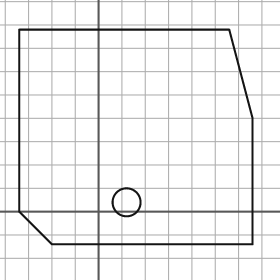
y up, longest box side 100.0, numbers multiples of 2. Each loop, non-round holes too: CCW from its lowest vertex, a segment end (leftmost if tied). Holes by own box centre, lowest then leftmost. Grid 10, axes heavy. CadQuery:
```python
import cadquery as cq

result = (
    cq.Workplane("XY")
    .moveTo(-20.0, -14.0)
    .lineTo(66.0, -14.0)
    .lineTo(66.0, 40.0)
    .lineTo(56.0, 78.0)
    .lineTo(-34.0, 78.0)
    .lineTo(-34.0, 0.0)
    .close()
    .moveTo(12.0, 4.0)
    .circle(6.0)
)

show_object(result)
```